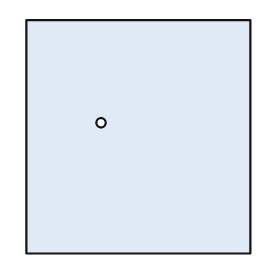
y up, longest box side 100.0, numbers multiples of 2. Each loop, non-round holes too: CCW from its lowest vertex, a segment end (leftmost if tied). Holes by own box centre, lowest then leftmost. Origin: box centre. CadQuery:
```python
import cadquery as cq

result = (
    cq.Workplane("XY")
    .moveTo(-48.0, -50.0)
    .lineTo(48.0, -50.0)
    .lineTo(48.0, 50.0)
    .lineTo(-48.0, 50.0)
    .close()
    .moveTo(-16.0, 6.0)
    .circle(2.0)
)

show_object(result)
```